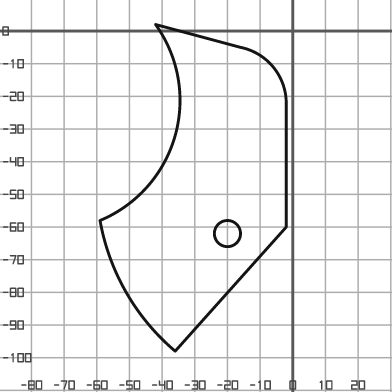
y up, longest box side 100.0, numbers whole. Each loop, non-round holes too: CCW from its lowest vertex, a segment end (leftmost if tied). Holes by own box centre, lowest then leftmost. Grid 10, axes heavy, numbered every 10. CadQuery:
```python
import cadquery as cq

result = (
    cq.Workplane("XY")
    .moveTo(-36.0, -98.0)
    .lineTo(-2.0, -60.0)
    .lineTo(-2.0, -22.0)
    .threePointArc((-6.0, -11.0), (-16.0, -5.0))
    .lineTo(-42.0, 2.0)
    .threePointArc((-36.0, -32.0), (-59.0, -58.0))
    .threePointArc((-51.0, -80.0), (-36.0, -98.0))
    .close()
    .moveTo(-20.0, -62.0)
    .circle(4.0)
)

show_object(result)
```